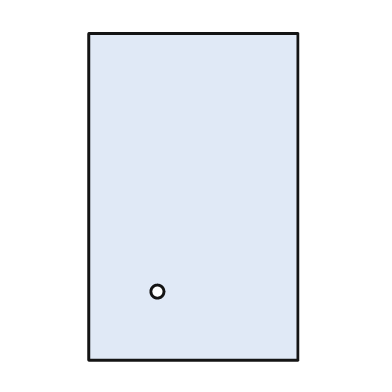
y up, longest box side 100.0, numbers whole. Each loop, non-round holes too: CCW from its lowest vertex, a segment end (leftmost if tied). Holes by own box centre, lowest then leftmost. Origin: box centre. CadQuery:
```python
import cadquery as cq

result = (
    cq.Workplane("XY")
    .moveTo(-32.0, -50.0)
    .lineTo(32.0, -50.0)
    .lineTo(32.0, 50.0)
    .lineTo(-32.0, 50.0)
    .close()
    .moveTo(-11.0, -29.0)
    .circle(2.0)
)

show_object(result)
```